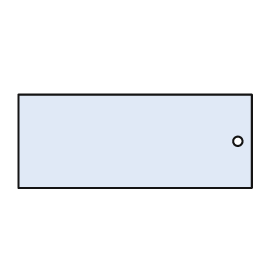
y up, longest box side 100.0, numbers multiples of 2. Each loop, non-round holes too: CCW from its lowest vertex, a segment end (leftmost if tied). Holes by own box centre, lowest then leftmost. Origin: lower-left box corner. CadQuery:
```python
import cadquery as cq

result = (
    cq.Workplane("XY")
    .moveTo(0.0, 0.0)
    .lineTo(100.0, 0.0)
    .lineTo(100.0, 40.0)
    .lineTo(0.0, 40.0)
    .close()
    .moveTo(94.0, 20.0)
    .circle(2.0)
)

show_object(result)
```